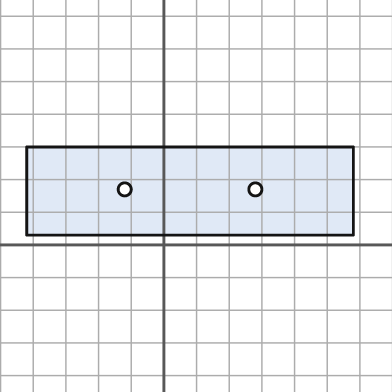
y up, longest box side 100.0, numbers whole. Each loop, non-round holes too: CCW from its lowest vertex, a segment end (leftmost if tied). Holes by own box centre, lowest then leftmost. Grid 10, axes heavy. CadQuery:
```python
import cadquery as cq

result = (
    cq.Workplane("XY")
    .moveTo(-42.0, 3.0)
    .lineTo(58.0, 3.0)
    .lineTo(58.0, 30.0)
    .lineTo(-42.0, 30.0)
    .close()
    .moveTo(-12.0, 17.0)
    .circle(2.0)
    .moveTo(28.0, 17.0)
    .circle(2.0)
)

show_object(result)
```